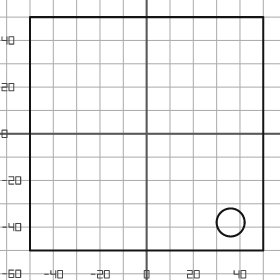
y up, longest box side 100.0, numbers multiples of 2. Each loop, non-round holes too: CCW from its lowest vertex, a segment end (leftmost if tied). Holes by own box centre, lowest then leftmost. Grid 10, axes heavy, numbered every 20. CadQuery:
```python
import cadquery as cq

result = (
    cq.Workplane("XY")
    .moveTo(-50.0, -50.0)
    .lineTo(50.0, -50.0)
    .lineTo(50.0, 50.0)
    .lineTo(-50.0, 50.0)
    .close()
    .moveTo(36.0, -38.0)
    .circle(6.0)
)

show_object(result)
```